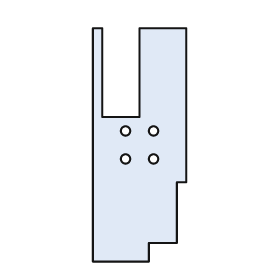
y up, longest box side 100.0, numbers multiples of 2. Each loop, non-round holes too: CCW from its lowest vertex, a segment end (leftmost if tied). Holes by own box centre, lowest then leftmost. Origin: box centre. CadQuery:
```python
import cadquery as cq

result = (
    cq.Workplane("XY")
    .moveTo(-20.0, -50.0)
    .lineTo(4.0, -50.0)
    .lineTo(4.0, -42.0)
    .lineTo(16.0, -42.0)
    .lineTo(16.0, -16.0)
    .lineTo(20.0, -16.0)
    .lineTo(20.0, 50.0)
    .lineTo(0.0, 50.0)
    .lineTo(0.0, 12.0)
    .lineTo(-16.0, 12.0)
    .lineTo(-16.0, 50.0)
    .lineTo(-20.0, 50.0)
    .close()
    .moveTo(-6.0, -6.0)
    .circle(2.0)
    .moveTo(6.0, -6.0)
    .circle(2.0)
    .moveTo(-6.0, 6.0)
    .circle(2.0)
    .moveTo(6.0, 6.0)
    .circle(2.0)
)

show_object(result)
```